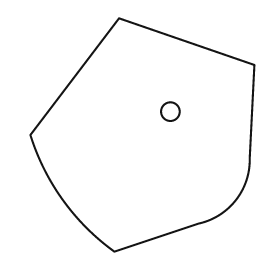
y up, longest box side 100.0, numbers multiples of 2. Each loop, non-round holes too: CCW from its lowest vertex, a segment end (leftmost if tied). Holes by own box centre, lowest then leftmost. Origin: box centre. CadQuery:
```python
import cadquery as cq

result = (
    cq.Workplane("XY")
    .moveTo(-12.0, -50.0)
    .lineTo(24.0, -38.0)
    .threePointArc((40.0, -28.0), (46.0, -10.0))
    .lineTo(48.0, 30.0)
    .lineTo(-10.0, 50.0)
    .lineTo(-48.0, 0.0)
    .threePointArc((-34.0, -28.0), (-12.0, -50.0))
    .close()
    .moveTo(12.0, 10.0)
    .circle(4.0)
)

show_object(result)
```